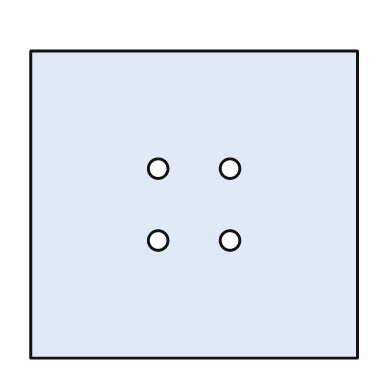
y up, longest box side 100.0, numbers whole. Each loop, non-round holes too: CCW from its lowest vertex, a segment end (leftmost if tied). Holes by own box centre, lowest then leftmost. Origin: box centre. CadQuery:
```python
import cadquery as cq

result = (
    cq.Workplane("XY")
    .moveTo(-50.0, -47.0)
    .lineTo(50.0, -47.0)
    .lineTo(50.0, 47.0)
    .lineTo(-50.0, 47.0)
    .close()
    .moveTo(-11.0, -11.0)
    .circle(3.0)
    .moveTo(11.0, -11.0)
    .circle(3.0)
    .moveTo(-11.0, 11.0)
    .circle(3.0)
    .moveTo(11.0, 11.0)
    .circle(3.0)
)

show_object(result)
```